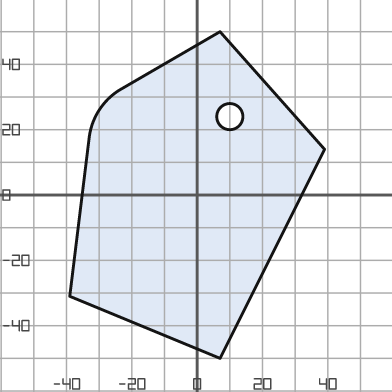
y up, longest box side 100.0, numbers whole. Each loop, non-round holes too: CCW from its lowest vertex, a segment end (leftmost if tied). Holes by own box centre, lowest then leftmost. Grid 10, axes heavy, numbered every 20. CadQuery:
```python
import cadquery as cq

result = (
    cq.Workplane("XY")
    .moveTo(7.0, -50.0)
    .lineTo(39.0, 14.0)
    .lineTo(7.0, 50.0)
    .lineTo(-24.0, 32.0)
    .threePointArc((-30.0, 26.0), (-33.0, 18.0))
    .lineTo(-39.0, -31.0)
    .close()
    .moveTo(10.0, 24.0)
    .circle(4.0)
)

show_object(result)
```